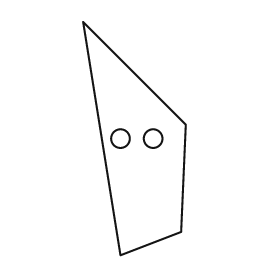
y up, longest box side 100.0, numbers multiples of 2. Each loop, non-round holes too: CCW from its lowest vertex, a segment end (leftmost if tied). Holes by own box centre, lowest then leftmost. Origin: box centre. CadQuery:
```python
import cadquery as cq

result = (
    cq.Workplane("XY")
    .moveTo(-6.0, -50.0)
    .lineTo(20.0, -40.0)
    .lineTo(22.0, 6.0)
    .lineTo(-22.0, 50.0)
    .close()
    .moveTo(-6.0, 0.0)
    .circle(4.0)
    .moveTo(8.0, 0.0)
    .circle(4.0)
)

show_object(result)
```